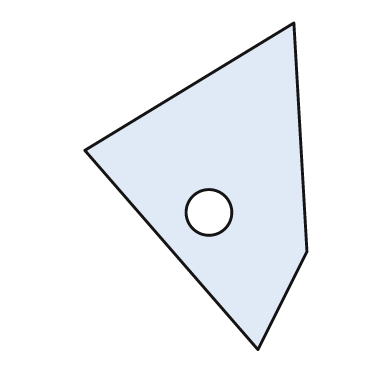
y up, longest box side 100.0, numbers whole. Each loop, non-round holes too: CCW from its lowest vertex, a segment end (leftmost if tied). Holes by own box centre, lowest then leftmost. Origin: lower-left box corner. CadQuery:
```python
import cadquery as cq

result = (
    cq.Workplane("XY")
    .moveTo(53.0, 0.0)
    .lineTo(68.0, 30.0)
    .lineTo(64.0, 100.0)
    .lineTo(0.0, 61.0)
    .close()
    .moveTo(38.0, 42.0)
    .circle(7.0)
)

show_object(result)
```